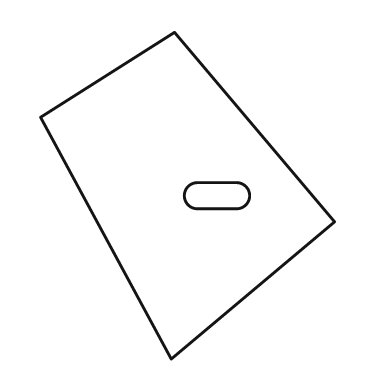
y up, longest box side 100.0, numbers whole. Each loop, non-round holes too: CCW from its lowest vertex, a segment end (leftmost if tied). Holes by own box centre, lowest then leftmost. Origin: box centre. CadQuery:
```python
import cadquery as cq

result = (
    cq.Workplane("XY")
    .moveTo(-5.0, -50.0)
    .lineTo(45.0, -8.0)
    .lineTo(-4.0, 50.0)
    .lineTo(-45.0, 24.0)
    .close()
    .moveTo(3.0, -4.0)
    .lineTo(15.0, -4.0)
    .threePointArc((19.0, 0.0), (15.0, 4.0))
    .lineTo(3.0, 4.0)
    .threePointArc((-1.0, 0.0), (3.0, -4.0))
    .close()
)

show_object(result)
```